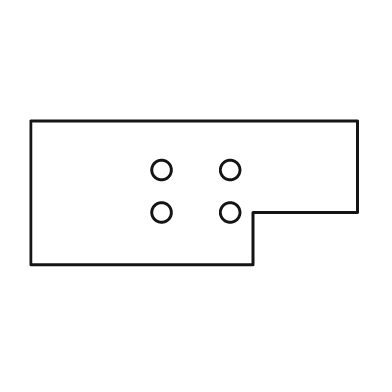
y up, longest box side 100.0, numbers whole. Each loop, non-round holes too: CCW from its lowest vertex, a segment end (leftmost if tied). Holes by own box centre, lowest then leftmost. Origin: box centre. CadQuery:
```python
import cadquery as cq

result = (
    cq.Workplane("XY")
    .moveTo(-50.0, -22.0)
    .lineTo(18.0, -22.0)
    .lineTo(18.0, -6.0)
    .lineTo(50.0, -6.0)
    .lineTo(50.0, 22.0)
    .lineTo(-50.0, 22.0)
    .close()
    .moveTo(-10.0, -6.0)
    .circle(3.0)
    .moveTo(11.0, -6.0)
    .circle(3.0)
    .moveTo(-10.0, 7.0)
    .circle(3.0)
    .moveTo(11.0, 7.0)
    .circle(3.0)
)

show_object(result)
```